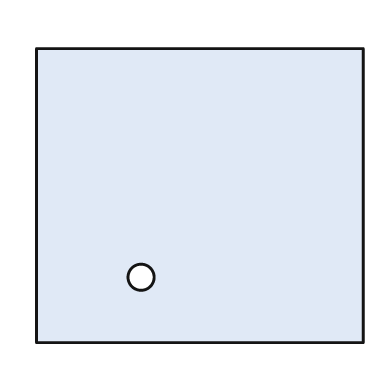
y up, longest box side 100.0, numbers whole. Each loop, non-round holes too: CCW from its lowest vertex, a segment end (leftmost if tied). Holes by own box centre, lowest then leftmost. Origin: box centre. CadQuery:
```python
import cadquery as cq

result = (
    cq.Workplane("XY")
    .moveTo(-50.0, -45.0)
    .lineTo(50.0, -45.0)
    .lineTo(50.0, 45.0)
    .lineTo(-50.0, 45.0)
    .close()
    .moveTo(-18.0, -25.0)
    .circle(4.0)
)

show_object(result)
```